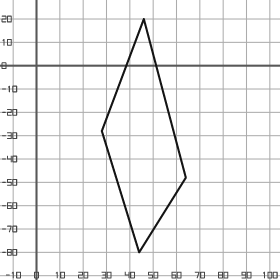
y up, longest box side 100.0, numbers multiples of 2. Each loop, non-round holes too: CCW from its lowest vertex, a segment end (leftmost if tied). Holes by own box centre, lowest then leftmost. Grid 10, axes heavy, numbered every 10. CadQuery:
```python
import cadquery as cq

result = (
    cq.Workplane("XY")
    .moveTo(44.0, -80.0)
    .lineTo(64.0, -48.0)
    .lineTo(46.0, 20.0)
    .lineTo(28.0, -28.0)
    .close()
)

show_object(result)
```